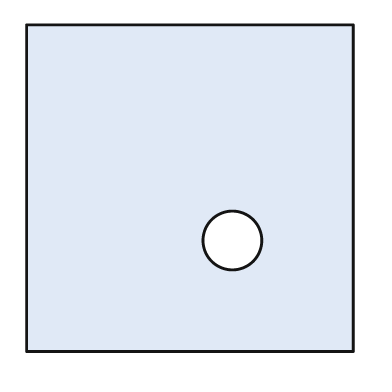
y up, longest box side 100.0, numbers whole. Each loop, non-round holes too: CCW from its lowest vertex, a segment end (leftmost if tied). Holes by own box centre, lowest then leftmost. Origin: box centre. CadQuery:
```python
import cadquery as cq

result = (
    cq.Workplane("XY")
    .moveTo(-50.0, -50.0)
    .lineTo(50.0, -50.0)
    .lineTo(50.0, 50.0)
    .lineTo(-50.0, 50.0)
    .close()
    .moveTo(13.0, -16.0)
    .circle(9.0)
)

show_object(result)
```